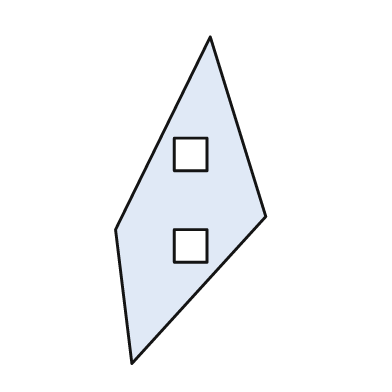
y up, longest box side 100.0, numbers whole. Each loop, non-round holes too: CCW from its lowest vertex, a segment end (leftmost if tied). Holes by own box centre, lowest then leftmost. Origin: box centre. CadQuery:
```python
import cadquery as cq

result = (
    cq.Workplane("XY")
    .moveTo(-18.0, -50.0)
    .lineTo(23.0, -5.0)
    .lineTo(6.0, 50.0)
    .lineTo(-23.0, -9.0)
    .close()
    .moveTo(-5.0, -19.0)
    .lineTo(5.0, -19.0)
    .lineTo(5.0, -9.0)
    .lineTo(-5.0, -9.0)
    .close()
    .moveTo(-5.0, 9.0)
    .lineTo(5.0, 9.0)
    .lineTo(5.0, 19.0)
    .lineTo(-5.0, 19.0)
    .close()
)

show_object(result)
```